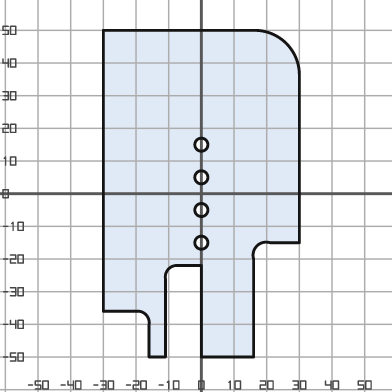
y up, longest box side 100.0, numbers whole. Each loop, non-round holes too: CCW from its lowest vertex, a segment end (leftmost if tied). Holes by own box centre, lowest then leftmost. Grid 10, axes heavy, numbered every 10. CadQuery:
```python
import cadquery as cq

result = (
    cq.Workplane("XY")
    .moveTo(-16.0, -50.0)
    .lineTo(-11.0, -50.0)
    .lineTo(-11.0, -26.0)
    .threePointArc((-10.0, -23.0), (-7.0, -22.0))
    .lineTo(0.0, -22.0)
    .lineTo(0.0, -50.0)
    .lineTo(16.0, -50.0)
    .lineTo(16.0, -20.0)
    .threePointArc((17.0, -16.0), (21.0, -15.0))
    .lineTo(30.0, -15.0)
    .lineTo(30.0, 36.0)
    .threePointArc((26.0, 46.0), (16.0, 50.0))
    .lineTo(-30.0, 50.0)
    .lineTo(-30.0, -36.0)
    .lineTo(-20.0, -36.0)
    .threePointArc((-17.0, -37.0), (-16.0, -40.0))
    .close()
    .moveTo(0.0, -15.0)
    .circle(2.0)
    .moveTo(0.0, -5.0)
    .circle(2.0)
    .moveTo(0.0, 5.0)
    .circle(2.0)
    .moveTo(0.0, 15.0)
    .circle(2.0)
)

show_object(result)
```